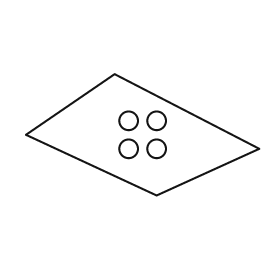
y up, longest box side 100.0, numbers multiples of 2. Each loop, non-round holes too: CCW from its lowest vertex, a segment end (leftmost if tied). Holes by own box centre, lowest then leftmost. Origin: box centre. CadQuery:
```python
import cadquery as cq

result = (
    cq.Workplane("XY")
    .moveTo(6.0, -26.0)
    .lineTo(50.0, -6.0)
    .lineTo(-12.0, 26.0)
    .lineTo(-50.0, 0.0)
    .close()
    .moveTo(-6.0, -6.0)
    .circle(4.0)
    .moveTo(6.0, -6.0)
    .circle(4.0)
    .moveTo(-6.0, 6.0)
    .circle(4.0)
    .moveTo(6.0, 6.0)
    .circle(4.0)
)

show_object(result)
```